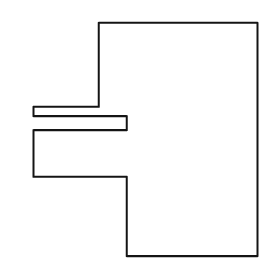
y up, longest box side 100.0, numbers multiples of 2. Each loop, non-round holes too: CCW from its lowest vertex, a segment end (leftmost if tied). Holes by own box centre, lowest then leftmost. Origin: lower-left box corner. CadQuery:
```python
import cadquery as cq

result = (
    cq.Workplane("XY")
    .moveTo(40.0, 0.0)
    .lineTo(96.0, 0.0)
    .lineTo(96.0, 100.0)
    .lineTo(28.0, 100.0)
    .lineTo(28.0, 64.0)
    .lineTo(0.0, 64.0)
    .lineTo(0.0, 60.0)
    .lineTo(40.0, 60.0)
    .lineTo(40.0, 54.0)
    .lineTo(0.0, 54.0)
    .lineTo(0.0, 34.0)
    .lineTo(40.0, 34.0)
    .close()
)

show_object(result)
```